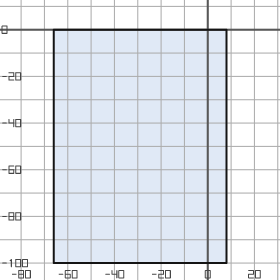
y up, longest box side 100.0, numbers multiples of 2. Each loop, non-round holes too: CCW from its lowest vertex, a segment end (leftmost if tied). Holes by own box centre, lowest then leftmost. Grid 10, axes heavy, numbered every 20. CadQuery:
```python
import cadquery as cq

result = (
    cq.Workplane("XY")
    .moveTo(-66.0, -100.0)
    .lineTo(8.0, -100.0)
    .lineTo(8.0, 0.0)
    .lineTo(-66.0, 0.0)
    .close()
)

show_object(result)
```